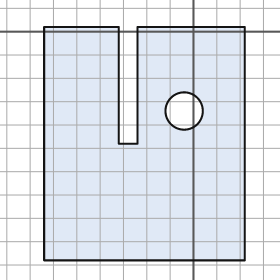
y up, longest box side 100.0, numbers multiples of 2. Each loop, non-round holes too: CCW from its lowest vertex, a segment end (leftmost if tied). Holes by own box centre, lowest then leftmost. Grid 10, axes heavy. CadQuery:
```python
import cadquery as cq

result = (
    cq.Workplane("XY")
    .moveTo(-64.0, -98.0)
    .lineTo(22.0, -98.0)
    .lineTo(22.0, 2.0)
    .lineTo(-24.0, 2.0)
    .lineTo(-24.0, -48.0)
    .lineTo(-32.0, -48.0)
    .lineTo(-32.0, 2.0)
    .lineTo(-64.0, 2.0)
    .close()
    .moveTo(-4.0, -34.0)
    .circle(8.0)
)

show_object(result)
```